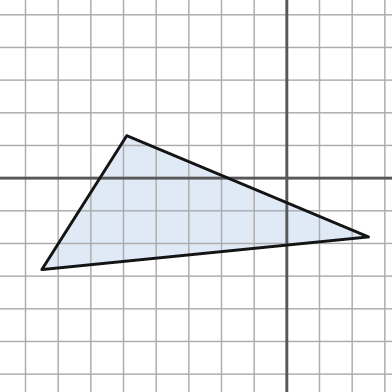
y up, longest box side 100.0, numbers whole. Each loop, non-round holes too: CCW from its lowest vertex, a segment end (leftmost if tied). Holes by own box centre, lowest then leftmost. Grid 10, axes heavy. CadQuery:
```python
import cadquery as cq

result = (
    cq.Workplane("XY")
    .moveTo(-75.0, -28.0)
    .lineTo(25.0, -18.0)
    .lineTo(-49.0, 13.0)
    .close()
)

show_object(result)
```